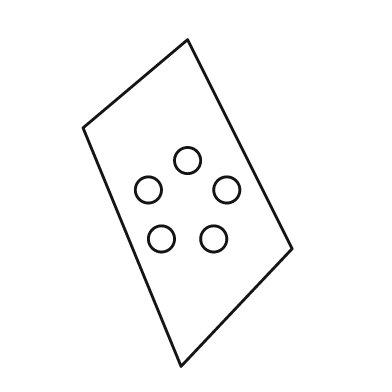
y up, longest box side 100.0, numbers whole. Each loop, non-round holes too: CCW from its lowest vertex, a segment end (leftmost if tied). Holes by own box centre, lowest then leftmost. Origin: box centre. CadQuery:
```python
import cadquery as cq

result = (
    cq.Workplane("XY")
    .moveTo(-2.0, -50.0)
    .lineTo(32.0, -14.0)
    .lineTo(0.0, 50.0)
    .lineTo(-32.0, 23.0)
    .close()
    .moveTo(-8.0, -11.0)
    .circle(4.0)
    .moveTo(8.0, -11.0)
    .circle(4.0)
    .moveTo(-12.0, 4.0)
    .circle(4.0)
    .moveTo(12.0, 4.0)
    .circle(4.0)
    .moveTo(0.0, 13.0)
    .circle(4.0)
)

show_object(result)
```